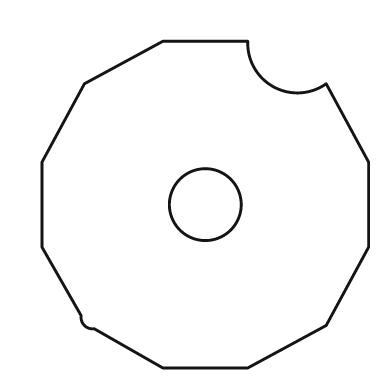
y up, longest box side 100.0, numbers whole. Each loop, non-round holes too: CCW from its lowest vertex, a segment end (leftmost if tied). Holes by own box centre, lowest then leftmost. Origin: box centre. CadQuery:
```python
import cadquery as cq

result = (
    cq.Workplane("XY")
    .moveTo(-13.0, -50.0)
    .lineTo(13.0, -50.0)
    .lineTo(37.0, -37.0)
    .lineTo(50.0, -13.0)
    .lineTo(50.0, 13.0)
    .lineTo(37.0, 37.0)
    .threePointArc((21.0, 36.0), (13.0, 50.0))
    .lineTo(-13.0, 50.0)
    .lineTo(-37.0, 37.0)
    .lineTo(-50.0, 13.0)
    .lineTo(-50.0, -13.0)
    .lineTo(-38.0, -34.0)
    .threePointArc((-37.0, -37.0), (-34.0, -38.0))
    .close()
    .moveTo(0.0, 0.0)
    .circle(11.0)
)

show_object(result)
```